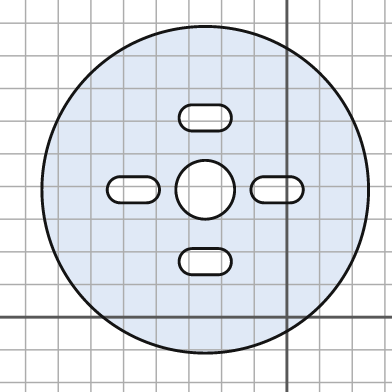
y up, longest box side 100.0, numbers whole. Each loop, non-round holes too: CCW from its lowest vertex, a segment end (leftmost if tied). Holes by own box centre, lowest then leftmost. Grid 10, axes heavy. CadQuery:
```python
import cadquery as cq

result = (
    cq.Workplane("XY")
    .moveTo(-25.0, 39.0)
    .circle(50.0)
    .moveTo(-29.0, 13.0)
    .lineTo(-21.0, 13.0)
    .threePointArc((-17.0, 17.0), (-21.0, 21.0))
    .lineTo(-29.0, 21.0)
    .threePointArc((-33.0, 17.0), (-29.0, 13.0))
    .close()
    .moveTo(-51.0, 35.0)
    .lineTo(-43.0, 35.0)
    .threePointArc((-39.0, 39.0), (-43.0, 43.0))
    .lineTo(-51.0, 43.0)
    .threePointArc((-55.0, 39.0), (-51.0, 35.0))
    .close()
    .moveTo(-25.0, 39.0)
    .circle(9.0)
    .moveTo(-7.0, 35.0)
    .lineTo(1.0, 35.0)
    .threePointArc((5.0, 39.0), (1.0, 43.0))
    .lineTo(-7.0, 43.0)
    .threePointArc((-11.0, 39.0), (-7.0, 35.0))
    .close()
    .moveTo(-29.0, 57.0)
    .lineTo(-21.0, 57.0)
    .threePointArc((-17.0, 61.0), (-21.0, 65.0))
    .lineTo(-29.0, 65.0)
    .threePointArc((-33.0, 61.0), (-29.0, 57.0))
    .close()
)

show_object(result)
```